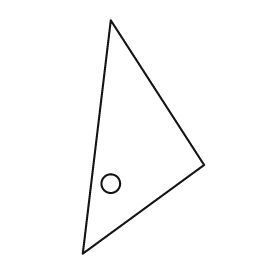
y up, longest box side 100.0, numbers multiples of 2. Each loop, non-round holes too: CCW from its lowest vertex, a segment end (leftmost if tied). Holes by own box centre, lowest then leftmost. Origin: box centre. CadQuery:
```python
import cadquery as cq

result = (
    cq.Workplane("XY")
    .moveTo(-26.0, -50.0)
    .lineTo(26.0, -12.0)
    .lineTo(-14.0, 50.0)
    .close()
    .moveTo(-14.0, -20.0)
    .circle(4.0)
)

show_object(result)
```